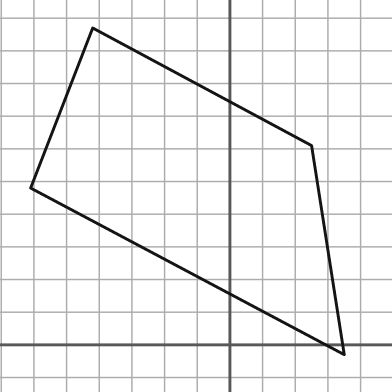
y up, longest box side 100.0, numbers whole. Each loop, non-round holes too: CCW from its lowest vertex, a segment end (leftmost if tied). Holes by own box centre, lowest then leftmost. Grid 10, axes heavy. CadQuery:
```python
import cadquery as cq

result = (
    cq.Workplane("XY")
    .moveTo(35.0, -3.0)
    .lineTo(25.0, 61.0)
    .lineTo(-42.0, 97.0)
    .lineTo(-61.0, 48.0)
    .close()
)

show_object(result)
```